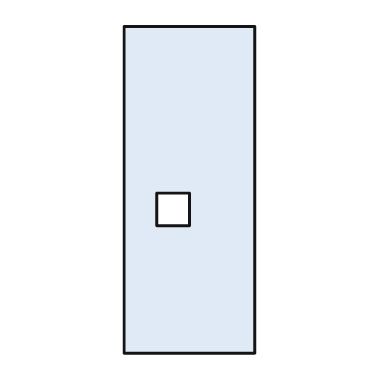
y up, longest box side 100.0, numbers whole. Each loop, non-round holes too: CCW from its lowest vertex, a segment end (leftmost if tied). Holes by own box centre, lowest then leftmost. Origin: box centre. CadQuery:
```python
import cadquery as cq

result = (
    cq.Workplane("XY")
    .moveTo(-20.0, -50.0)
    .lineTo(20.0, -50.0)
    .lineTo(20.0, 50.0)
    .lineTo(-20.0, 50.0)
    .close()
    .moveTo(-10.0, -11.0)
    .lineTo(0.0, -11.0)
    .lineTo(0.0, -1.0)
    .lineTo(-10.0, -1.0)
    .close()
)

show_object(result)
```